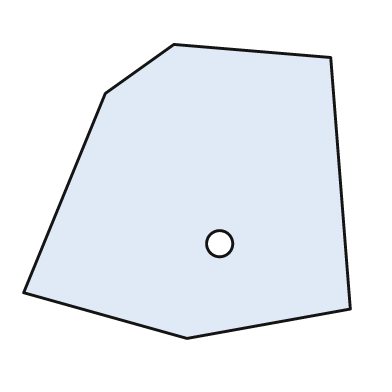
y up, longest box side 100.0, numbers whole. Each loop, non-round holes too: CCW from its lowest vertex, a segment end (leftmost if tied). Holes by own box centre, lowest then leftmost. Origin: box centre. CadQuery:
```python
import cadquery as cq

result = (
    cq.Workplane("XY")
    .moveTo(0.0, -45.0)
    .lineTo(50.0, -36.0)
    .lineTo(44.0, 41.0)
    .lineTo(-4.0, 45.0)
    .lineTo(-25.0, 30.0)
    .lineTo(-50.0, -31.0)
    .close()
    .moveTo(10.0, -16.0)
    .circle(4.0)
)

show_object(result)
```